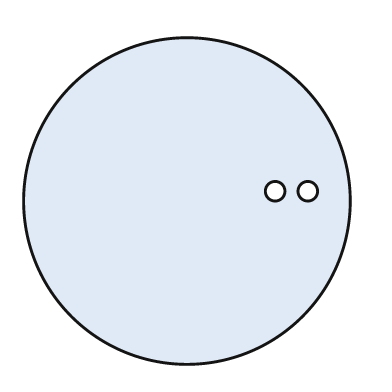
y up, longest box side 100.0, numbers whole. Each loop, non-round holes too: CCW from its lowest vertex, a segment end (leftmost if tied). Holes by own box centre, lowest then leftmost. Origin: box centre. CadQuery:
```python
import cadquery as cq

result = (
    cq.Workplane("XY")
    .moveTo(0.0, 0.0)
    .circle(50.0)
    .moveTo(27.0, 3.0)
    .circle(3.0)
    .moveTo(37.0, 3.0)
    .circle(3.0)
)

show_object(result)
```